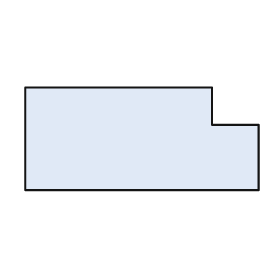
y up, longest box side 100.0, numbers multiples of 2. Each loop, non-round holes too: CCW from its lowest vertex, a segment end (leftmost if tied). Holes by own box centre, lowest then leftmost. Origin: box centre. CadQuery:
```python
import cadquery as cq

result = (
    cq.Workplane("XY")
    .moveTo(-50.0, -22.0)
    .lineTo(50.0, -22.0)
    .lineTo(50.0, 6.0)
    .lineTo(30.0, 6.0)
    .lineTo(30.0, 22.0)
    .lineTo(-50.0, 22.0)
    .close()
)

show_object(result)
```